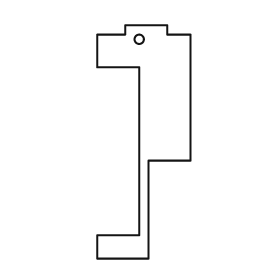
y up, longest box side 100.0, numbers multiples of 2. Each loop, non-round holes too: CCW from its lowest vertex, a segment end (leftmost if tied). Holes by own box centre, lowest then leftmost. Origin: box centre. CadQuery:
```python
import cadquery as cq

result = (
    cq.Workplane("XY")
    .moveTo(-20.0, -50.0)
    .lineTo(2.0, -50.0)
    .lineTo(2.0, -8.0)
    .lineTo(20.0, -8.0)
    .lineTo(20.0, 46.0)
    .lineTo(10.0, 46.0)
    .lineTo(10.0, 50.0)
    .lineTo(-8.0, 50.0)
    .lineTo(-8.0, 46.0)
    .lineTo(-20.0, 46.0)
    .lineTo(-20.0, 32.0)
    .lineTo(-2.0, 32.0)
    .lineTo(-2.0, -40.0)
    .lineTo(-20.0, -40.0)
    .close()
    .moveTo(-2.0, 44.0)
    .circle(2.0)
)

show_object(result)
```